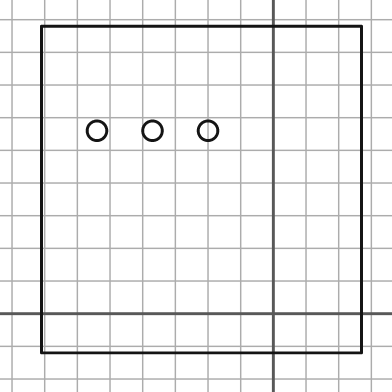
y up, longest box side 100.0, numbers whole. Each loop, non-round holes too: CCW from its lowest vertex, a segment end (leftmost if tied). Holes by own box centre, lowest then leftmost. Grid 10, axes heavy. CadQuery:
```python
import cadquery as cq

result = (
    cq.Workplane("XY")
    .moveTo(-71.0, -12.0)
    .lineTo(27.0, -12.0)
    .lineTo(27.0, 88.0)
    .lineTo(-71.0, 88.0)
    .close()
    .moveTo(-54.0, 56.0)
    .circle(3.0)
    .moveTo(-37.0, 56.0)
    .circle(3.0)
    .moveTo(-20.0, 56.0)
    .circle(3.0)
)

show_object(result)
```